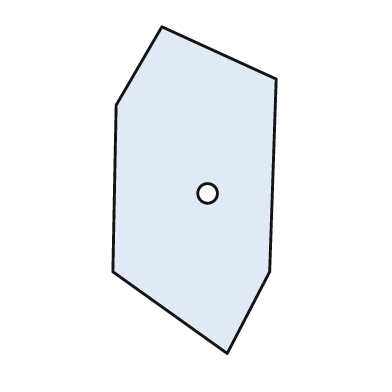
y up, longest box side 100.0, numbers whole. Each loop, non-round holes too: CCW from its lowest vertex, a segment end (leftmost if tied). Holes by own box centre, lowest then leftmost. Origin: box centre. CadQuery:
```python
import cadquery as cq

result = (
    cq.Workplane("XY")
    .moveTo(10.0, -50.0)
    .lineTo(23.0, -25.0)
    .lineTo(25.0, 34.0)
    .lineTo(-10.0, 50.0)
    .lineTo(-24.0, 26.0)
    .lineTo(-25.0, -25.0)
    .close()
    .moveTo(4.0, -1.0)
    .circle(3.0)
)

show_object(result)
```